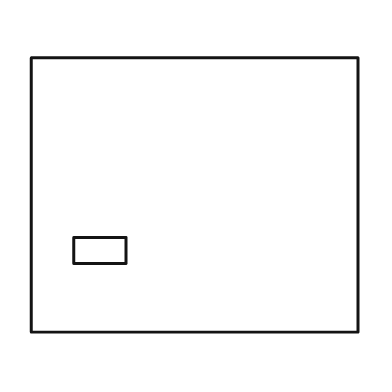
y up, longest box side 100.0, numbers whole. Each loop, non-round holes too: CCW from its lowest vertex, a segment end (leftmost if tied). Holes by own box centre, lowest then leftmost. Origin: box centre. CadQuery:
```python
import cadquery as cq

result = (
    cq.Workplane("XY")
    .moveTo(-50.0, -42.0)
    .lineTo(50.0, -42.0)
    .lineTo(50.0, 42.0)
    .lineTo(-50.0, 42.0)
    .close()
    .moveTo(-37.0, -21.0)
    .lineTo(-21.0, -21.0)
    .lineTo(-21.0, -13.0)
    .lineTo(-37.0, -13.0)
    .close()
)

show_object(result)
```